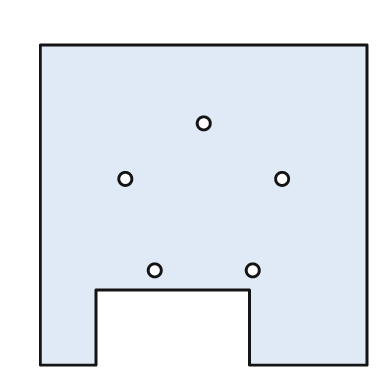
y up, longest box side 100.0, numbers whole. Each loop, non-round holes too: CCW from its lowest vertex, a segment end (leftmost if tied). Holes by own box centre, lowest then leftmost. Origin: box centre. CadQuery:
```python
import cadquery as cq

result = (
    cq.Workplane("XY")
    .moveTo(-50.0, -49.0)
    .lineTo(-33.0, -49.0)
    .lineTo(-33.0, -26.0)
    .lineTo(14.0, -26.0)
    .lineTo(14.0, -49.0)
    .lineTo(50.0, -49.0)
    .lineTo(50.0, 49.0)
    .lineTo(-50.0, 49.0)
    .close()
    .moveTo(-15.0, -20.0)
    .circle(2.0)
    .moveTo(15.0, -20.0)
    .circle(2.0)
    .moveTo(-24.0, 8.0)
    .circle(2.0)
    .moveTo(24.0, 8.0)
    .circle(2.0)
    .moveTo(0.0, 25.0)
    .circle(2.0)
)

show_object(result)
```